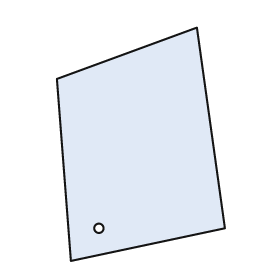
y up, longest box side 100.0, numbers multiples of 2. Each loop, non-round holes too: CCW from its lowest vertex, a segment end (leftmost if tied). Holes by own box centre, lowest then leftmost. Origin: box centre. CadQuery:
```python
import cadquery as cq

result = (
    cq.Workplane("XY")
    .moveTo(-30.0, -50.0)
    .lineTo(36.0, -36.0)
    .lineTo(24.0, 50.0)
    .lineTo(-36.0, 28.0)
    .close()
    .moveTo(-18.0, -36.0)
    .circle(2.0)
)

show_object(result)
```